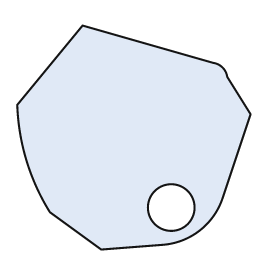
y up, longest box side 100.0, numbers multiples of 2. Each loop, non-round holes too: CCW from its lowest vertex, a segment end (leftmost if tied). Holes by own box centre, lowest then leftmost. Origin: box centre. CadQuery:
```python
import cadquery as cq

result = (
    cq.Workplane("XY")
    .moveTo(-14.0, -48.0)
    .lineTo(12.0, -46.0)
    .threePointArc((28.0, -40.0), (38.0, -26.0))
    .lineTo(50.0, 10.0)
    .lineTo(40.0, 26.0)
    .threePointArc((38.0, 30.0), (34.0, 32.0))
    .lineTo(-22.0, 48.0)
    .lineTo(-50.0, 14.0)
    .threePointArc((-46.0, -10.0), (-36.0, -32.0))
    .close()
    .moveTo(16.0, -30.0)
    .circle(10.0)
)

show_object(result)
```